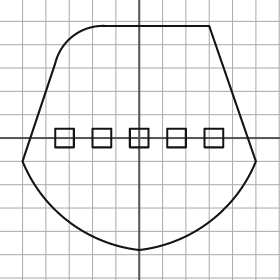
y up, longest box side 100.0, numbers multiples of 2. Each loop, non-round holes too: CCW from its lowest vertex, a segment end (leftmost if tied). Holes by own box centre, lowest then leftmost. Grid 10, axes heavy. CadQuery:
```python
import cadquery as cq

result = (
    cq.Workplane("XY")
    .moveTo(0.0, -48.0)
    .threePointArc((30.0, -36.0), (50.0, -10.0))
    .lineTo(30.0, 48.0)
    .lineTo(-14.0, 48.0)
    .threePointArc((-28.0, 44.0), (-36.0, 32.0))
    .lineTo(-50.0, -10.0)
    .threePointArc((-30.0, -36.0), (0.0, -48.0))
    .close()
    .moveTo(-36.0, -4.0)
    .lineTo(-28.0, -4.0)
    .lineTo(-28.0, 4.0)
    .lineTo(-36.0, 4.0)
    .close()
    .moveTo(-20.0, -4.0)
    .lineTo(-12.0, -4.0)
    .lineTo(-12.0, 4.0)
    .lineTo(-20.0, 4.0)
    .close()
    .moveTo(-4.0, -4.0)
    .lineTo(4.0, -4.0)
    .lineTo(4.0, 4.0)
    .lineTo(-4.0, 4.0)
    .close()
    .moveTo(12.0, -4.0)
    .lineTo(20.0, -4.0)
    .lineTo(20.0, 4.0)
    .lineTo(12.0, 4.0)
    .close()
    .moveTo(28.0, -4.0)
    .lineTo(36.0, -4.0)
    .lineTo(36.0, 4.0)
    .lineTo(28.0, 4.0)
    .close()
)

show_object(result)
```